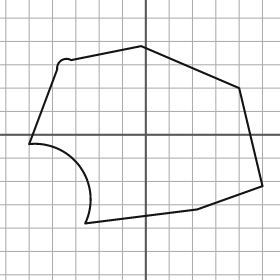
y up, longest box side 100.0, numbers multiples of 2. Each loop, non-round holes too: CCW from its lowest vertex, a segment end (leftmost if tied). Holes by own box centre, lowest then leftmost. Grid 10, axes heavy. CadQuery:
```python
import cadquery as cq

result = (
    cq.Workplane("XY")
    .moveTo(-26.0, -38.0)
    .lineTo(22.0, -32.0)
    .lineTo(50.0, -22.0)
    .lineTo(40.0, 20.0)
    .lineTo(-2.0, 38.0)
    .lineTo(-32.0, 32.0)
    .threePointArc((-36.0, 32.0), (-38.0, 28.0))
    .lineTo(-50.0, -4.0)
    .threePointArc((-28.0, -14.0), (-26.0, -38.0))
    .close()
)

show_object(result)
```